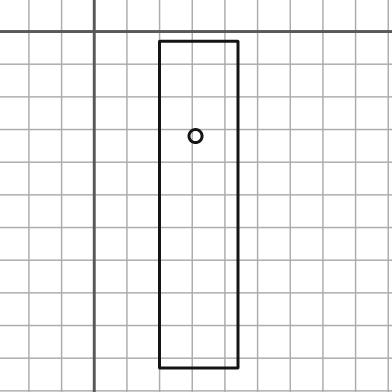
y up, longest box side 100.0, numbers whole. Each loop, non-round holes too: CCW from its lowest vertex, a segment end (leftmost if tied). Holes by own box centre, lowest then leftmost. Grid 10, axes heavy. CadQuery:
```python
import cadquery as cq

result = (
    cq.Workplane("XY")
    .moveTo(20.0, -103.0)
    .lineTo(44.0, -103.0)
    .lineTo(44.0, -3.0)
    .lineTo(20.0, -3.0)
    .close()
    .moveTo(31.0, -32.0)
    .circle(2.0)
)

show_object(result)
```